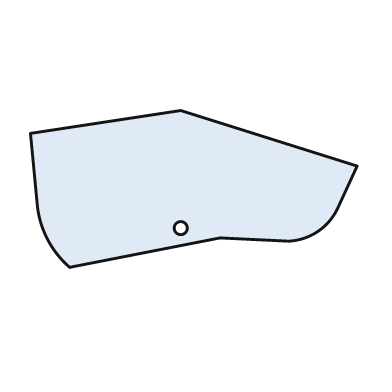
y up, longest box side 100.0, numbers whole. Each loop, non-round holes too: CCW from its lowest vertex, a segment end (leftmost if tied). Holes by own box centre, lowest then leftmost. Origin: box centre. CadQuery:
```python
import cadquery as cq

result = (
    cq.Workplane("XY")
    .moveTo(-38.0, -24.0)
    .lineTo(8.0, -15.0)
    .lineTo(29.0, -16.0)
    .threePointArc((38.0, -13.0), (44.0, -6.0))
    .lineTo(50.0, 7.0)
    .lineTo(-4.0, 24.0)
    .lineTo(-50.0, 17.0)
    .lineTo(-48.0, -4.0)
    .threePointArc((-45.0, -15.0), (-38.0, -24.0))
    .close()
    .moveTo(-4.0, -12.0)
    .circle(2.0)
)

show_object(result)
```